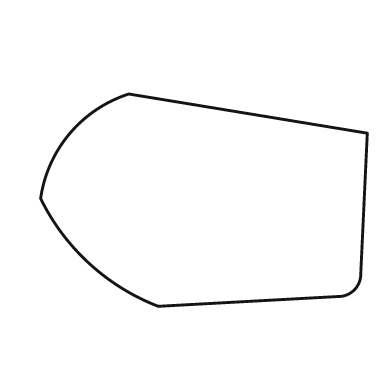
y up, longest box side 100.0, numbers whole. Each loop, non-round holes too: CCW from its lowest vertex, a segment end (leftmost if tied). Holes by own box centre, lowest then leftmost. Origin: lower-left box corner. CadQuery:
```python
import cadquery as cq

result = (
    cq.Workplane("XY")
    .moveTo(36.0, 0.0)
    .lineTo(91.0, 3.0)
    .threePointArc((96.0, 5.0), (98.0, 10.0))
    .lineTo(100.0, 53.0)
    .lineTo(27.0, 65.0)
    .threePointArc((9.0, 53.0), (0.0, 33.0))
    .threePointArc((15.0, 13.0), (36.0, 0.0))
    .close()
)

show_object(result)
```